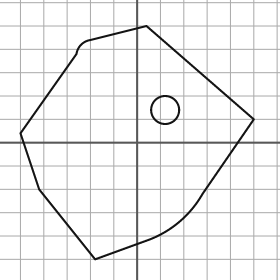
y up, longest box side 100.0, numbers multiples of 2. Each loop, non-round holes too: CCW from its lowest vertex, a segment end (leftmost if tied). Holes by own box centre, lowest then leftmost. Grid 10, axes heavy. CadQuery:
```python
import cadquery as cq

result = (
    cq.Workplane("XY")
    .moveTo(-18.0, -50.0)
    .lineTo(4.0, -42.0)
    .threePointArc((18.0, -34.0), (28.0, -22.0))
    .lineTo(50.0, 10.0)
    .lineTo(4.0, 50.0)
    .lineTo(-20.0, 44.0)
    .threePointArc((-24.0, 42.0), (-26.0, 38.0))
    .lineTo(-50.0, 4.0)
    .lineTo(-42.0, -20.0)
    .close()
    .moveTo(12.0, 14.0)
    .circle(6.0)
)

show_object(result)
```